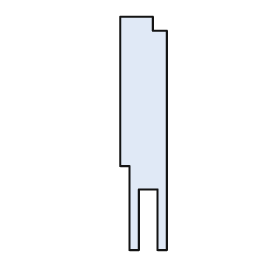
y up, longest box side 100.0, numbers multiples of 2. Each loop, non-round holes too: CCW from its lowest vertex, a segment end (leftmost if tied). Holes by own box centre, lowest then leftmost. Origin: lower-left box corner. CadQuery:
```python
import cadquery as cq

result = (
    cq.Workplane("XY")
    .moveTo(4.0, 0.0)
    .lineTo(8.0, 0.0)
    .lineTo(8.0, 26.0)
    .lineTo(16.0, 26.0)
    .lineTo(16.0, 0.0)
    .lineTo(20.0, 0.0)
    .lineTo(20.0, 94.0)
    .lineTo(14.0, 94.0)
    .lineTo(14.0, 100.0)
    .lineTo(0.0, 100.0)
    .lineTo(0.0, 36.0)
    .lineTo(4.0, 36.0)
    .close()
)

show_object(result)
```